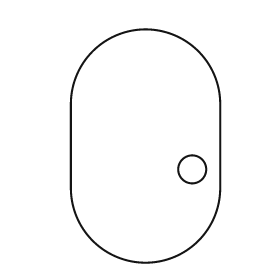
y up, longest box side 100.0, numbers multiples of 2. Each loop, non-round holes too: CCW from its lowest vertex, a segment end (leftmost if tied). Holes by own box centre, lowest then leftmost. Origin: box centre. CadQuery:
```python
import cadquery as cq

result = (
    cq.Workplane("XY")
    .moveTo(-32.0, -18.0)
    .threePointArc((0.0, -50.0), (32.0, -18.0))
    .lineTo(32.0, 18.0)
    .threePointArc((0.0, 50.0), (-32.0, 18.0))
    .close()
    .moveTo(20.0, -10.0)
    .circle(6.0)
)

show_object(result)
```